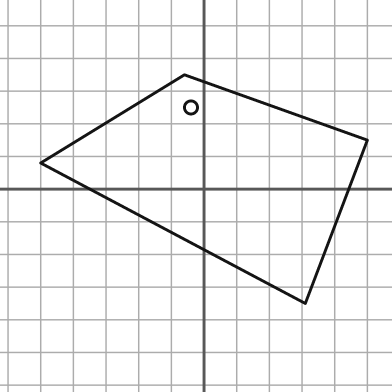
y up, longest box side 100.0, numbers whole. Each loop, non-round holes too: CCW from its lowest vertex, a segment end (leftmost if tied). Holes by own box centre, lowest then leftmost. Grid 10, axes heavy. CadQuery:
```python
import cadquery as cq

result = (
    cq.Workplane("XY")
    .moveTo(31.0, -35.0)
    .lineTo(50.0, 15.0)
    .lineTo(-6.0, 35.0)
    .lineTo(-50.0, 8.0)
    .close()
    .moveTo(-4.0, 25.0)
    .circle(2.0)
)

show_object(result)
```